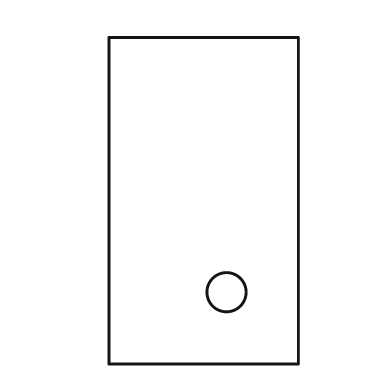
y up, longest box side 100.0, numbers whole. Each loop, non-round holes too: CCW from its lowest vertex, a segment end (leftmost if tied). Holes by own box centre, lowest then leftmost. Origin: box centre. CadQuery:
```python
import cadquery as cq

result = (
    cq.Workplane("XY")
    .moveTo(-29.0, -50.0)
    .lineTo(29.0, -50.0)
    .lineTo(29.0, 50.0)
    .lineTo(-29.0, 50.0)
    .close()
    .moveTo(7.0, -28.0)
    .circle(6.0)
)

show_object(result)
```